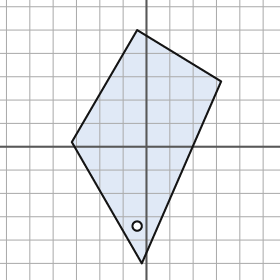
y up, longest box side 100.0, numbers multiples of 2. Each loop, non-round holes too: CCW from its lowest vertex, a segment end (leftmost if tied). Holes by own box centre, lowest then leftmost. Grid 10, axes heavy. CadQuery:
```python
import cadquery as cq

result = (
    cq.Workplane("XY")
    .moveTo(-2.0, -50.0)
    .lineTo(32.0, 28.0)
    .lineTo(-4.0, 50.0)
    .lineTo(-32.0, 2.0)
    .close()
    .moveTo(-4.0, -34.0)
    .circle(2.0)
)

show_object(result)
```